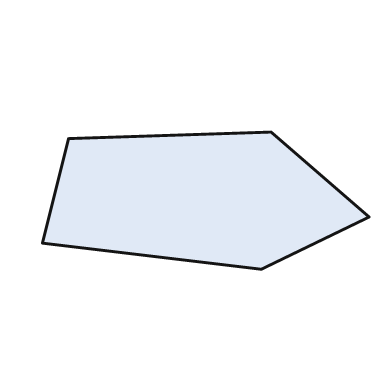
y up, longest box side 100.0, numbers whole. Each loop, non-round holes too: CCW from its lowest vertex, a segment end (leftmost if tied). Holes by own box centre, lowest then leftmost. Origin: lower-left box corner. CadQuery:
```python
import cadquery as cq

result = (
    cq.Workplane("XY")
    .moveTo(67.0, 0.0)
    .lineTo(100.0, 16.0)
    .lineTo(70.0, 42.0)
    .lineTo(8.0, 40.0)
    .lineTo(0.0, 8.0)
    .close()
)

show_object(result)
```